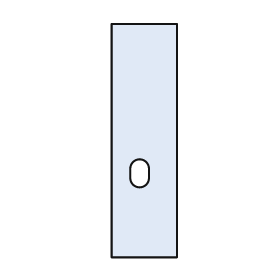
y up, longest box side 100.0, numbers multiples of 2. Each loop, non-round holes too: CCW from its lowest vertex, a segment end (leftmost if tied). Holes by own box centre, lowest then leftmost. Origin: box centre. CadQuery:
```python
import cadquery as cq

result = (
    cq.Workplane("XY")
    .moveTo(-14.0, -50.0)
    .lineTo(14.0, -50.0)
    .lineTo(14.0, 50.0)
    .lineTo(-14.0, 50.0)
    .close()
    .moveTo(-6.0, -16.0)
    .threePointArc((-2.0, -20.0), (2.0, -16.0))
    .lineTo(2.0, -12.0)
    .threePointArc((-2.0, -8.0), (-6.0, -12.0))
    .close()
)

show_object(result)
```